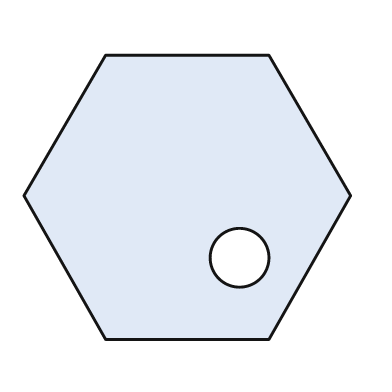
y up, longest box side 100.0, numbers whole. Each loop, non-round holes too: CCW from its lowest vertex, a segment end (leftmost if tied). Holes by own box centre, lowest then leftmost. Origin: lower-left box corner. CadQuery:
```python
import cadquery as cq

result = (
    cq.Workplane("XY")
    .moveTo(25.0, 0.0)
    .lineTo(75.0, 0.0)
    .lineTo(100.0, 44.0)
    .lineTo(75.0, 87.0)
    .lineTo(25.0, 87.0)
    .lineTo(0.0, 44.0)
    .close()
    .moveTo(66.0, 25.0)
    .circle(9.0)
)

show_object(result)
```